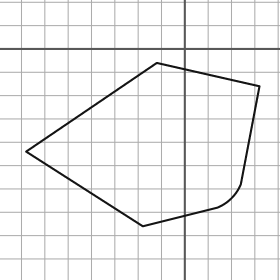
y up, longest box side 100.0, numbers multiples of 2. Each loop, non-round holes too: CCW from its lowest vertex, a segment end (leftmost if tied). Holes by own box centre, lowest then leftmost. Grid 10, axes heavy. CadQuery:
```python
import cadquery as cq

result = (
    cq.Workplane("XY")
    .moveTo(-18.0, -76.0)
    .lineTo(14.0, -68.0)
    .threePointArc((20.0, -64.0), (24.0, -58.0))
    .lineTo(32.0, -16.0)
    .lineTo(-12.0, -6.0)
    .lineTo(-68.0, -44.0)
    .close()
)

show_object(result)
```